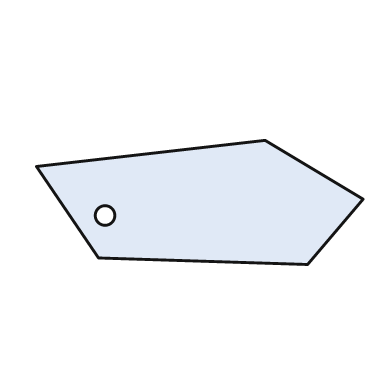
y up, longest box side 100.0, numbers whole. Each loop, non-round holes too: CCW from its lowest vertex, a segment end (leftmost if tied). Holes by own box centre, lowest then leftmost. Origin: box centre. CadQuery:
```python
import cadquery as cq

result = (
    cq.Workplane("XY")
    .moveTo(33.0, -19.0)
    .lineTo(50.0, 1.0)
    .lineTo(20.0, 19.0)
    .lineTo(-50.0, 11.0)
    .lineTo(-31.0, -17.0)
    .close()
    .moveTo(-29.0, -4.0)
    .circle(3.0)
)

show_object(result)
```